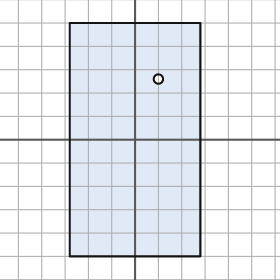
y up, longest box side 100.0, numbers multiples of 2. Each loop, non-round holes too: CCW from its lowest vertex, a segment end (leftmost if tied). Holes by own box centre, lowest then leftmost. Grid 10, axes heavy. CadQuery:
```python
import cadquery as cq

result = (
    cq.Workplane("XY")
    .moveTo(-28.0, -50.0)
    .lineTo(28.0, -50.0)
    .lineTo(28.0, 50.0)
    .lineTo(-28.0, 50.0)
    .close()
    .moveTo(10.0, 26.0)
    .circle(2.0)
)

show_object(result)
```